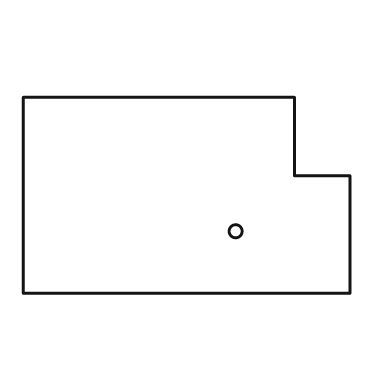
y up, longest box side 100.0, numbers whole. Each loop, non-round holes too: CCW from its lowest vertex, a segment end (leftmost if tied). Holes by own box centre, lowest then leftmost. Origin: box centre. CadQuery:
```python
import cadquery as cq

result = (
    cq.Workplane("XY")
    .moveTo(-50.0, -30.0)
    .lineTo(50.0, -30.0)
    .lineTo(50.0, 6.0)
    .lineTo(33.0, 6.0)
    .lineTo(33.0, 30.0)
    .lineTo(-50.0, 30.0)
    .close()
    .moveTo(15.0, -11.0)
    .circle(2.0)
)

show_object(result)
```